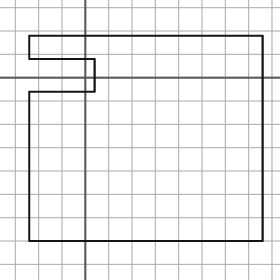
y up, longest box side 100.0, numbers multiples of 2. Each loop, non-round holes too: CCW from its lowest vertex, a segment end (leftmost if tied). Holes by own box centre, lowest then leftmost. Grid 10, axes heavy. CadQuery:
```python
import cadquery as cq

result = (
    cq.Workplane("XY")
    .moveTo(-24.0, -70.0)
    .lineTo(76.0, -70.0)
    .lineTo(76.0, 18.0)
    .lineTo(-24.0, 18.0)
    .lineTo(-24.0, 8.0)
    .lineTo(4.0, 8.0)
    .lineTo(4.0, -6.0)
    .lineTo(-24.0, -6.0)
    .close()
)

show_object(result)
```